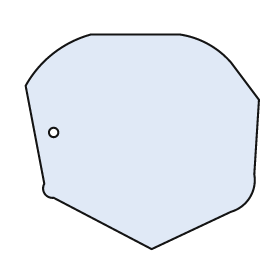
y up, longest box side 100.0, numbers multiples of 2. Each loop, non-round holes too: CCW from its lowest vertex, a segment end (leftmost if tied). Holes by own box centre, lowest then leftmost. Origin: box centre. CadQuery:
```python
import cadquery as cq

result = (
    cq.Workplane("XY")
    .moveTo(4.0, -46.0)
    .lineTo(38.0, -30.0)
    .threePointArc((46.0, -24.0), (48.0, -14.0))
    .lineTo(50.0, 18.0)
    .lineTo(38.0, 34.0)
    .threePointArc((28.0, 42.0), (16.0, 46.0))
    .lineTo(-22.0, 46.0)
    .threePointArc((-38.0, 38.0), (-50.0, 24.0))
    .lineTo(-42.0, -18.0)
    .threePointArc((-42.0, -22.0), (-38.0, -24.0))
    .close()
    .moveTo(-38.0, 4.0)
    .circle(2.0)
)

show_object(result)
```